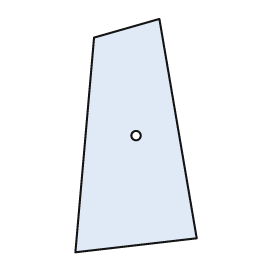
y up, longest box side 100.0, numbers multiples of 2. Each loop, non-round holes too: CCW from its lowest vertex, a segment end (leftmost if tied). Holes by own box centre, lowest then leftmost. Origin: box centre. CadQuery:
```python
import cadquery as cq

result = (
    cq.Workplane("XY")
    .moveTo(-26.0, -50.0)
    .lineTo(26.0, -44.0)
    .lineTo(10.0, 50.0)
    .lineTo(-18.0, 42.0)
    .close()
    .moveTo(0.0, 0.0)
    .circle(2.0)
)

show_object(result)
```